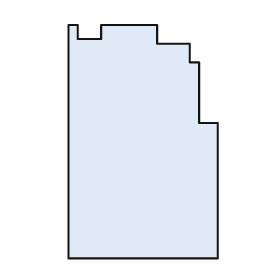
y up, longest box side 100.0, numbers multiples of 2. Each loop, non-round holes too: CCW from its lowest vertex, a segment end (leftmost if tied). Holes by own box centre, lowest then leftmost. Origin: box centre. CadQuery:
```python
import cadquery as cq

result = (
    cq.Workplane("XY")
    .moveTo(-32.0, -50.0)
    .lineTo(32.0, -50.0)
    .lineTo(32.0, 8.0)
    .lineTo(24.0, 8.0)
    .lineTo(24.0, 34.0)
    .lineTo(20.0, 34.0)
    .lineTo(20.0, 42.0)
    .lineTo(6.0, 42.0)
    .lineTo(6.0, 50.0)
    .lineTo(-18.0, 50.0)
    .lineTo(-18.0, 44.0)
    .lineTo(-28.0, 44.0)
    .lineTo(-28.0, 50.0)
    .lineTo(-32.0, 50.0)
    .close()
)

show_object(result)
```